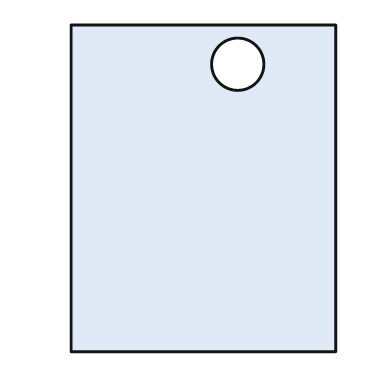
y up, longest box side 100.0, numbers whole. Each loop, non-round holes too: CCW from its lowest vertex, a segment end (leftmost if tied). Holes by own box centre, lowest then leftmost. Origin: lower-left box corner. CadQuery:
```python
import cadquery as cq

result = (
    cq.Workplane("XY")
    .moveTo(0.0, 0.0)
    .lineTo(81.0, 0.0)
    .lineTo(81.0, 100.0)
    .lineTo(0.0, 100.0)
    .close()
    .moveTo(51.0, 88.0)
    .circle(8.0)
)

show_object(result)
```